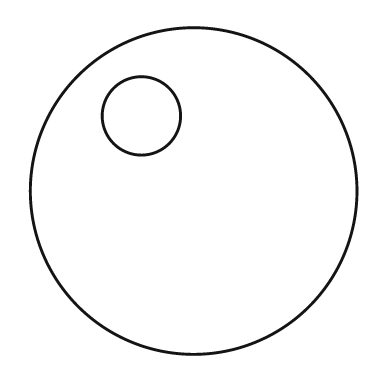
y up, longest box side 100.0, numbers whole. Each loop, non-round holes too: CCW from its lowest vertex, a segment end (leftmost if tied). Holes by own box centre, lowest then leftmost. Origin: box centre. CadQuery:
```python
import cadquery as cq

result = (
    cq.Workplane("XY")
    .moveTo(0.0, 0.0)
    .circle(50.0)
    .moveTo(-16.0, 23.0)
    .circle(12.0)
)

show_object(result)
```